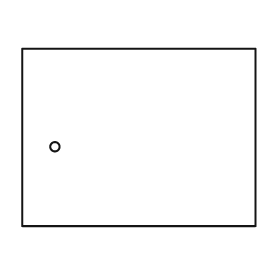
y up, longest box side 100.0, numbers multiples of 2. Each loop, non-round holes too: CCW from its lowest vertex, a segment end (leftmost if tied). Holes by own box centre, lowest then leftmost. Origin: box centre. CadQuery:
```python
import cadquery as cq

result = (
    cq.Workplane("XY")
    .moveTo(-50.0, -38.0)
    .lineTo(50.0, -38.0)
    .lineTo(50.0, 38.0)
    .lineTo(-50.0, 38.0)
    .close()
    .moveTo(-36.0, -4.0)
    .circle(2.0)
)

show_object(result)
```